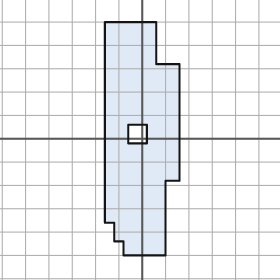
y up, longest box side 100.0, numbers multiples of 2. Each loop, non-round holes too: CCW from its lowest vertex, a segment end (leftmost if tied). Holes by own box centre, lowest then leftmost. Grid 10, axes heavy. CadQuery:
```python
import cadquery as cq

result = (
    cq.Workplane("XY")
    .moveTo(-8.0, -50.0)
    .lineTo(10.0, -50.0)
    .lineTo(10.0, -18.0)
    .lineTo(16.0, -18.0)
    .lineTo(16.0, 32.0)
    .lineTo(6.0, 32.0)
    .lineTo(6.0, 50.0)
    .lineTo(-16.0, 50.0)
    .lineTo(-16.0, -36.0)
    .lineTo(-12.0, -36.0)
    .lineTo(-12.0, -44.0)
    .lineTo(-8.0, -44.0)
    .close()
    .moveTo(-6.0, -2.0)
    .lineTo(2.0, -2.0)
    .lineTo(2.0, 6.0)
    .lineTo(-6.0, 6.0)
    .close()
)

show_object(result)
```